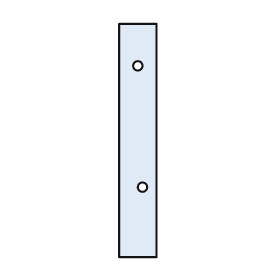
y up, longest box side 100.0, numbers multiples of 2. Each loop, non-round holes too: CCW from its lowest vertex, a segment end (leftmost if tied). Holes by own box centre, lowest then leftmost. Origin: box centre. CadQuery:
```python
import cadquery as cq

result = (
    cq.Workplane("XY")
    .moveTo(-8.0, -50.0)
    .lineTo(8.0, -50.0)
    .lineTo(8.0, 50.0)
    .lineTo(-8.0, 50.0)
    .close()
    .moveTo(2.0, -20.0)
    .circle(2.0)
    .moveTo(0.0, 32.0)
    .circle(2.0)
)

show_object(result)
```